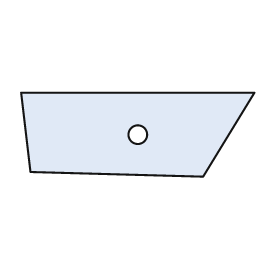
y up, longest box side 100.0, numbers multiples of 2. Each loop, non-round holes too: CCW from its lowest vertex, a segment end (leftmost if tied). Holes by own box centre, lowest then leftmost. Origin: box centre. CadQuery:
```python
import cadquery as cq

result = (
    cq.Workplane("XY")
    .moveTo(28.0, -18.0)
    .lineTo(50.0, 18.0)
    .lineTo(-50.0, 18.0)
    .lineTo(-46.0, -16.0)
    .close()
    .moveTo(0.0, 0.0)
    .circle(4.0)
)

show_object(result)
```